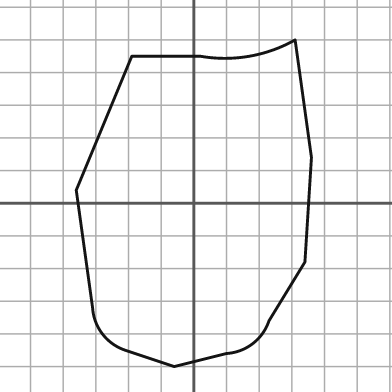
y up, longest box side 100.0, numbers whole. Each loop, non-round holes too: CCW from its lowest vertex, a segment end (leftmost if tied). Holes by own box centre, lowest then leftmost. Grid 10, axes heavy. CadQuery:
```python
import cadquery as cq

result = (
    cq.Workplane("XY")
    .moveTo(-6.0, -50.0)
    .lineTo(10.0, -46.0)
    .threePointArc((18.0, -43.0), (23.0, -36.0))
    .lineTo(34.0, -18.0)
    .lineTo(36.0, 14.0)
    .lineTo(31.0, 50.0)
    .threePointArc((17.0, 45.0), (2.0, 45.0))
    .lineTo(-19.0, 45.0)
    .lineTo(-36.0, 4.0)
    .lineTo(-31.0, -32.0)
    .threePointArc((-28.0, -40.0), (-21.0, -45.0))
    .close()
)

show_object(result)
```